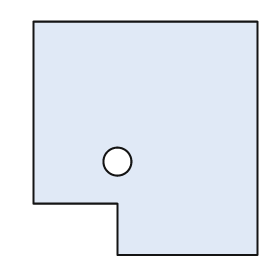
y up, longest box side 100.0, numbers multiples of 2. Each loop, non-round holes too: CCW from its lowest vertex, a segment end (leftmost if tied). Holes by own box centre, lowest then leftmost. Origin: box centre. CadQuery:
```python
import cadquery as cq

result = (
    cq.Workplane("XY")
    .moveTo(-12.0, -50.0)
    .lineTo(48.0, -50.0)
    .lineTo(48.0, 50.0)
    .lineTo(-48.0, 50.0)
    .lineTo(-48.0, -28.0)
    .lineTo(-12.0, -28.0)
    .close()
    .moveTo(-12.0, -10.0)
    .circle(6.0)
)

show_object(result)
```